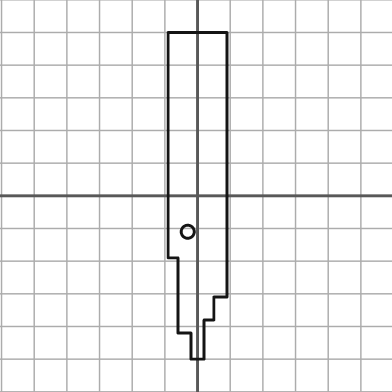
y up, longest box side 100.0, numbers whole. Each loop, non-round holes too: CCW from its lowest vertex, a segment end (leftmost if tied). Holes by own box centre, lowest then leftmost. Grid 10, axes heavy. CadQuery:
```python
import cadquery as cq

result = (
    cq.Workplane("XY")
    .moveTo(-2.0, -50.0)
    .lineTo(2.0, -50.0)
    .lineTo(2.0, -38.0)
    .lineTo(5.0, -38.0)
    .lineTo(5.0, -31.0)
    .lineTo(9.0, -31.0)
    .lineTo(9.0, 50.0)
    .lineTo(-9.0, 50.0)
    .lineTo(-9.0, -19.0)
    .lineTo(-6.0, -19.0)
    .lineTo(-6.0, -42.0)
    .lineTo(-2.0, -42.0)
    .close()
    .moveTo(-3.0, -11.0)
    .circle(2.0)
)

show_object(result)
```